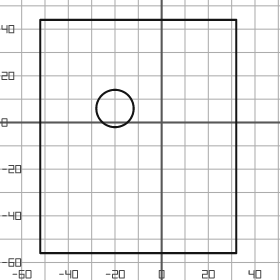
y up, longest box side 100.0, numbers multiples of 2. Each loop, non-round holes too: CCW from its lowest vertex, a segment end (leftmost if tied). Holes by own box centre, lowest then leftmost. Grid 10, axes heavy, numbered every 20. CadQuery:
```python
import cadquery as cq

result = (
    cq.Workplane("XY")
    .moveTo(-52.0, -56.0)
    .lineTo(32.0, -56.0)
    .lineTo(32.0, 44.0)
    .lineTo(-52.0, 44.0)
    .close()
    .moveTo(-20.0, 6.0)
    .circle(8.0)
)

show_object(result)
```